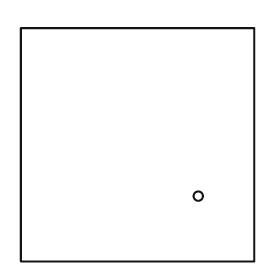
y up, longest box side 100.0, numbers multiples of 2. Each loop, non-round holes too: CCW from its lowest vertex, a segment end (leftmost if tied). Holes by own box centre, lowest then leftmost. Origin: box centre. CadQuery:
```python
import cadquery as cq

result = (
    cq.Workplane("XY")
    .moveTo(-50.0, -50.0)
    .lineTo(50.0, -50.0)
    .lineTo(50.0, 50.0)
    .lineTo(-50.0, 50.0)
    .close()
    .moveTo(26.0, -22.0)
    .circle(2.0)
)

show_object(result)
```